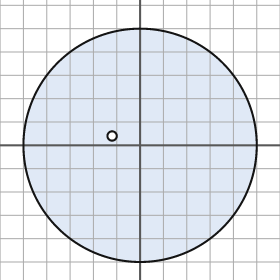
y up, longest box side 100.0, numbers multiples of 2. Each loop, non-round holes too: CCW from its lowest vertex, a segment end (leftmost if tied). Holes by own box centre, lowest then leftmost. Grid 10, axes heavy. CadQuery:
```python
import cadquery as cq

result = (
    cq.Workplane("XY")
    .moveTo(0.0, 0.0)
    .circle(50.0)
    .moveTo(-12.0, 4.0)
    .circle(2.0)
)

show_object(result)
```